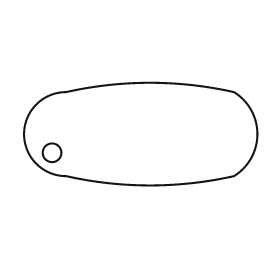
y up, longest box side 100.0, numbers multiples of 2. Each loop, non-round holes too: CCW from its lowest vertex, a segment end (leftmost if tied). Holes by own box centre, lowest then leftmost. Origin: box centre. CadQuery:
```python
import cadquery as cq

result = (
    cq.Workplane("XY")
    .moveTo(-32.0, -18.0)
    .threePointArc((4.0, -22.0), (40.0, -18.0))
    .threePointArc((50.0, 0.0), (40.0, 18.0))
    .threePointArc((4.0, 22.0), (-32.0, 18.0))
    .threePointArc((-50.0, 0.0), (-32.0, -18.0))
    .close()
    .moveTo(-38.0, -8.0)
    .circle(4.0)
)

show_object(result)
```